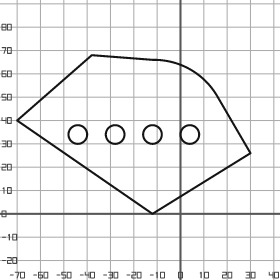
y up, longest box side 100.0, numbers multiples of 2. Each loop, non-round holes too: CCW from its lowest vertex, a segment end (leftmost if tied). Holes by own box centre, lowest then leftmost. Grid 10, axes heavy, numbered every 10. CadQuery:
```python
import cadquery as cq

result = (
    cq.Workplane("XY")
    .moveTo(-12.0, 0.0)
    .lineTo(30.0, 26.0)
    .lineTo(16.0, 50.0)
    .threePointArc((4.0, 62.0), (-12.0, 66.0))
    .lineTo(-38.0, 68.0)
    .lineTo(-70.0, 40.0)
    .close()
    .moveTo(-44.0, 34.0)
    .circle(4.0)
    .moveTo(-28.0, 34.0)
    .circle(4.0)
    .moveTo(-12.0, 34.0)
    .circle(4.0)
    .moveTo(4.0, 34.0)
    .circle(4.0)
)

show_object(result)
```